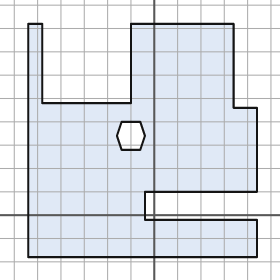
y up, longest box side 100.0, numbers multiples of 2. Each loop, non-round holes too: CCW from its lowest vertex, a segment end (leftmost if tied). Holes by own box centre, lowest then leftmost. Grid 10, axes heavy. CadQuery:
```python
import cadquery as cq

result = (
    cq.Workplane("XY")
    .moveTo(-54.0, -18.0)
    .lineTo(44.0, -18.0)
    .lineTo(44.0, -2.0)
    .lineTo(-4.0, -2.0)
    .lineTo(-4.0, 10.0)
    .lineTo(44.0, 10.0)
    .lineTo(44.0, 46.0)
    .lineTo(34.0, 46.0)
    .lineTo(34.0, 82.0)
    .lineTo(-10.0, 82.0)
    .lineTo(-10.0, 48.0)
    .lineTo(-48.0, 48.0)
    .lineTo(-48.0, 82.0)
    .lineTo(-54.0, 82.0)
    .close()
    .moveTo(-14.0, 28.0)
    .lineTo(-6.0, 28.0)
    .lineTo(-4.0, 34.0)
    .lineTo(-6.0, 40.0)
    .lineTo(-14.0, 40.0)
    .lineTo(-16.0, 34.0)
    .close()
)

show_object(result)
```